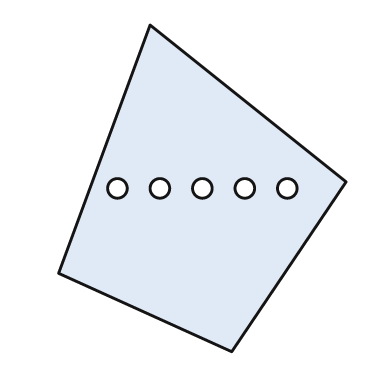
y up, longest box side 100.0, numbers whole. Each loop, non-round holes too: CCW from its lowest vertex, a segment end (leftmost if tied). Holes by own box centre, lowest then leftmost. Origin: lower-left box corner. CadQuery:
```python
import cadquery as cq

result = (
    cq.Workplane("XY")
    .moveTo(53.0, 0.0)
    .lineTo(88.0, 52.0)
    .lineTo(28.0, 100.0)
    .lineTo(0.0, 24.0)
    .close()
    .moveTo(18.0, 50.0)
    .circle(3.0)
    .moveTo(31.0, 50.0)
    .circle(3.0)
    .moveTo(44.0, 50.0)
    .circle(3.0)
    .moveTo(57.0, 50.0)
    .circle(3.0)
    .moveTo(70.0, 50.0)
    .circle(3.0)
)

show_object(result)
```